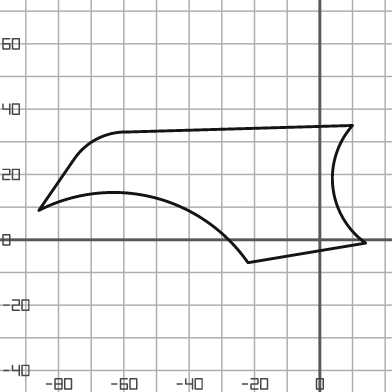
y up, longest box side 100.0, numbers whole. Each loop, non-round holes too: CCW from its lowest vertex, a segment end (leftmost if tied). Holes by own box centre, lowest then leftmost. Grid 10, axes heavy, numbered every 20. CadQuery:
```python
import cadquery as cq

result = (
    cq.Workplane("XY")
    .moveTo(-22.0, -7.0)
    .lineTo(14.0, -1.0)
    .threePointArc((4.0, 16.0), (10.0, 35.0))
    .lineTo(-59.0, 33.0)
    .threePointArc((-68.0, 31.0), (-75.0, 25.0))
    .lineTo(-86.0, 9.0)
    .threePointArc((-51.0, 13.0), (-22.0, -7.0))
    .close()
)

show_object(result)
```